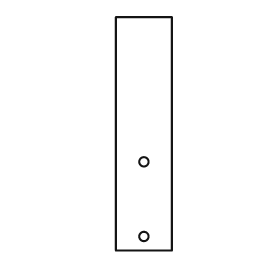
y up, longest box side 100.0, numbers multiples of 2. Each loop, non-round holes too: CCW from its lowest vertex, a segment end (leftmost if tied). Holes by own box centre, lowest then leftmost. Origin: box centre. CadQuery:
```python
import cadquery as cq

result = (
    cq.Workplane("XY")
    .moveTo(-12.0, -50.0)
    .lineTo(12.0, -50.0)
    .lineTo(12.0, 50.0)
    .lineTo(-12.0, 50.0)
    .close()
    .moveTo(0.0, -44.0)
    .circle(2.0)
    .moveTo(0.0, -12.0)
    .circle(2.0)
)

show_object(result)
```